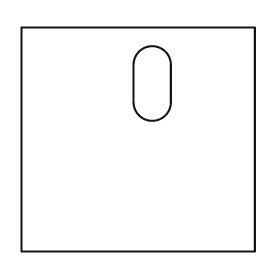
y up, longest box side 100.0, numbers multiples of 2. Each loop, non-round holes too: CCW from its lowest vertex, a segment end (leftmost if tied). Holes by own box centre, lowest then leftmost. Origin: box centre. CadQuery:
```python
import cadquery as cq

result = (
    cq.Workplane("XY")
    .moveTo(-50.0, -48.0)
    .lineTo(50.0, -48.0)
    .lineTo(50.0, 48.0)
    .lineTo(-50.0, 48.0)
    .close()
    .moveTo(-2.0, 16.0)
    .threePointArc((6.0, 8.0), (14.0, 16.0))
    .lineTo(14.0, 32.0)
    .threePointArc((6.0, 40.0), (-2.0, 32.0))
    .close()
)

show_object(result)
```